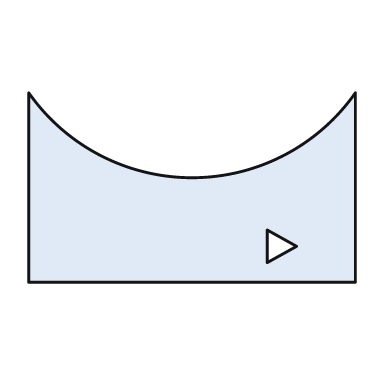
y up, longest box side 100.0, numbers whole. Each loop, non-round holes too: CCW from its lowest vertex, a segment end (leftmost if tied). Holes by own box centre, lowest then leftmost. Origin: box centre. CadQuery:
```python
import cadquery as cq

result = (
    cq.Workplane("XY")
    .moveTo(-50.0, -29.0)
    .lineTo(50.0, -29.0)
    .lineTo(50.0, 29.0)
    .threePointArc((0.0, 3.0), (-50.0, 29.0))
    .close()
    .moveTo(23.0, -23.0)
    .lineTo(32.0, -18.0)
    .lineTo(23.0, -13.0)
    .close()
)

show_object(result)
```